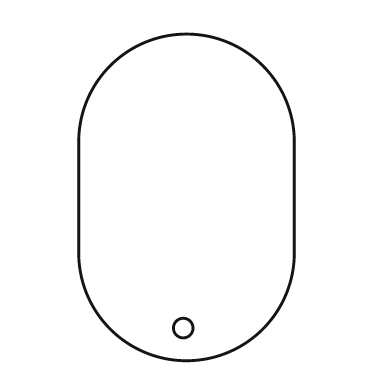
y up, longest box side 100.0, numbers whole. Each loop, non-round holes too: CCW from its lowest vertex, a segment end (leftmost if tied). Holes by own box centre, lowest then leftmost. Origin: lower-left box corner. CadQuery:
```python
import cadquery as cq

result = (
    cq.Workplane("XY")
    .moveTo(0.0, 33.0)
    .threePointArc((33.0, 0.0), (66.0, 33.0))
    .lineTo(66.0, 67.0)
    .threePointArc((33.0, 100.0), (0.0, 67.0))
    .close()
    .moveTo(32.0, 10.0)
    .circle(3.0)
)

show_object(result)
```